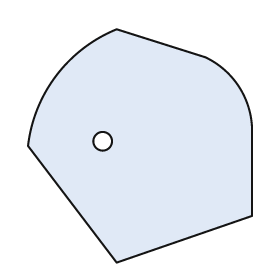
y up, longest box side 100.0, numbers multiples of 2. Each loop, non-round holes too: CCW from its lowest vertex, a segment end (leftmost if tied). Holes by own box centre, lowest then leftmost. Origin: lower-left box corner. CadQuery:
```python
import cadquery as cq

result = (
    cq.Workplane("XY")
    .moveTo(38.0, 0.0)
    .lineTo(96.0, 20.0)
    .lineTo(96.0, 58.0)
    .threePointArc((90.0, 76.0), (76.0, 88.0))
    .lineTo(38.0, 100.0)
    .threePointArc((12.0, 80.0), (0.0, 50.0))
    .close()
    .moveTo(32.0, 52.0)
    .circle(4.0)
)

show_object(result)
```